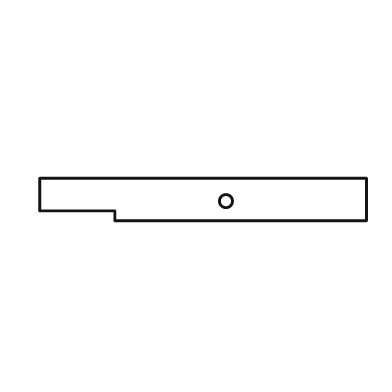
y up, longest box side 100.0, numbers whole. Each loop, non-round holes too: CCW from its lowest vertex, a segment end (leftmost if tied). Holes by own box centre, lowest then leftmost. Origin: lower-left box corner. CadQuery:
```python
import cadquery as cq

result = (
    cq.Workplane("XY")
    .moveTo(23.0, 0.0)
    .lineTo(100.0, 0.0)
    .lineTo(100.0, 13.0)
    .lineTo(0.0, 13.0)
    .lineTo(0.0, 3.0)
    .lineTo(23.0, 3.0)
    .close()
    .moveTo(57.0, 6.0)
    .circle(2.0)
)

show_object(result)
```